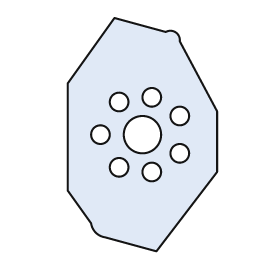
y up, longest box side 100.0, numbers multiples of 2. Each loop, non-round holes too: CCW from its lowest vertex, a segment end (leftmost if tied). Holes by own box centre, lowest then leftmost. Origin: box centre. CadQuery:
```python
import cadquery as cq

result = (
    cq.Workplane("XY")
    .moveTo(6.0, -50.0)
    .lineTo(32.0, -16.0)
    .lineTo(32.0, 10.0)
    .lineTo(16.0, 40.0)
    .threePointArc((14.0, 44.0), (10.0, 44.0))
    .lineTo(-12.0, 50.0)
    .lineTo(-32.0, 22.0)
    .lineTo(-32.0, -24.0)
    .lineTo(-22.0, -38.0)
    .threePointArc((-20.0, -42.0), (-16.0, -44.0))
    .close()
    .moveTo(4.0, -16.0)
    .circle(4.0)
    .moveTo(-10.0, -14.0)
    .circle(4.0)
    .moveTo(16.0, -8.0)
    .circle(4.0)
    .moveTo(-18.0, 0.0)
    .circle(4.0)
    .moveTo(0.0, 0.0)
    .circle(8.0)
    .moveTo(16.0, 8.0)
    .circle(4.0)
    .moveTo(-10.0, 14.0)
    .circle(4.0)
    .moveTo(4.0, 16.0)
    .circle(4.0)
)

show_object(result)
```